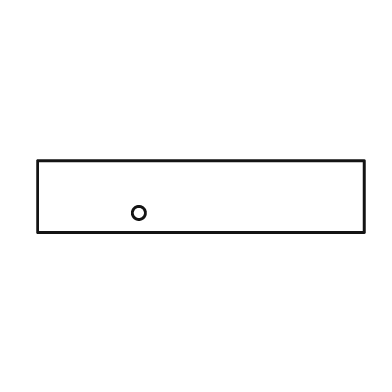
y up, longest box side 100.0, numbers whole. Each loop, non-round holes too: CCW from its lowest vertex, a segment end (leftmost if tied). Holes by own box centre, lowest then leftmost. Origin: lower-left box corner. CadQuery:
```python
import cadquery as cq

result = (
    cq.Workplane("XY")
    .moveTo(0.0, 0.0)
    .lineTo(100.0, 0.0)
    .lineTo(100.0, 22.0)
    .lineTo(0.0, 22.0)
    .close()
    .moveTo(31.0, 6.0)
    .circle(2.0)
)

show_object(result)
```